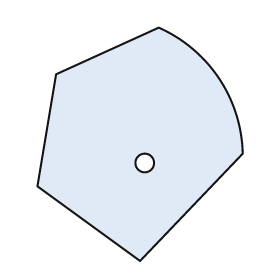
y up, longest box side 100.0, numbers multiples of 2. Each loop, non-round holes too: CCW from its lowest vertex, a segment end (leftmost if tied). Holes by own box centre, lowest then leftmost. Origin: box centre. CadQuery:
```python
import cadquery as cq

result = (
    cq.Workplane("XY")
    .moveTo(0.0, -50.0)
    .lineTo(44.0, -4.0)
    .threePointArc((34.0, 28.0), (8.0, 50.0))
    .lineTo(-36.0, 30.0)
    .lineTo(-44.0, -18.0)
    .close()
    .moveTo(2.0, -8.0)
    .circle(4.0)
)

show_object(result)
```